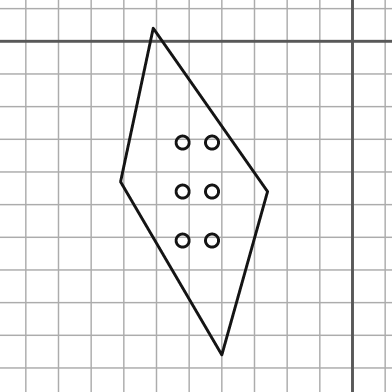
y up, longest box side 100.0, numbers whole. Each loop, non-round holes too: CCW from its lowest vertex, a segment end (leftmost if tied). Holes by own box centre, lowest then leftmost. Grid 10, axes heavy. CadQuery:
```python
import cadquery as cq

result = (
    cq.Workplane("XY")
    .moveTo(-40.0, -96.0)
    .lineTo(-26.0, -46.0)
    .lineTo(-61.0, 4.0)
    .lineTo(-71.0, -43.0)
    .close()
    .moveTo(-52.0, -61.0)
    .circle(2.0)
    .moveTo(-43.0, -61.0)
    .circle(2.0)
    .moveTo(-52.0, -46.0)
    .circle(2.0)
    .moveTo(-43.0, -46.0)
    .circle(2.0)
    .moveTo(-52.0, -31.0)
    .circle(2.0)
    .moveTo(-43.0, -31.0)
    .circle(2.0)
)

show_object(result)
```